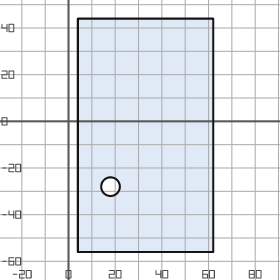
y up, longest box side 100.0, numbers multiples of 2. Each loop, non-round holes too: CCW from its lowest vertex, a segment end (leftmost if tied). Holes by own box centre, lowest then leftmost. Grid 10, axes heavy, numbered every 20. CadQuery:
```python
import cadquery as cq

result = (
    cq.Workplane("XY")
    .moveTo(4.0, -56.0)
    .lineTo(62.0, -56.0)
    .lineTo(62.0, 44.0)
    .lineTo(4.0, 44.0)
    .close()
    .moveTo(18.0, -28.0)
    .circle(4.0)
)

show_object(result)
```